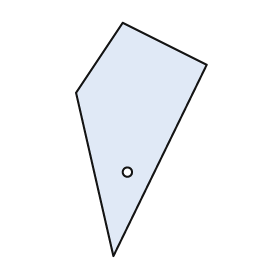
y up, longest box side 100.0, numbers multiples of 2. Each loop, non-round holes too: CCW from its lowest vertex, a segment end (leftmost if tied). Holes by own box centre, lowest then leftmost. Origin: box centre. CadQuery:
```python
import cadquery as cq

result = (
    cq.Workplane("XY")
    .moveTo(-12.0, -50.0)
    .lineTo(28.0, 32.0)
    .lineTo(-8.0, 50.0)
    .lineTo(-28.0, 20.0)
    .close()
    .moveTo(-6.0, -14.0)
    .circle(2.0)
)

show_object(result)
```